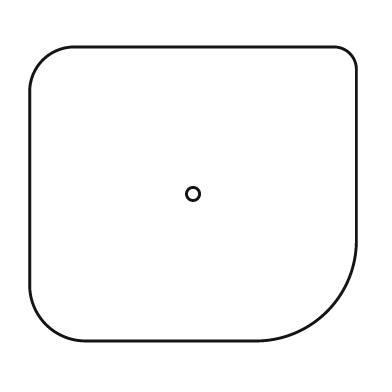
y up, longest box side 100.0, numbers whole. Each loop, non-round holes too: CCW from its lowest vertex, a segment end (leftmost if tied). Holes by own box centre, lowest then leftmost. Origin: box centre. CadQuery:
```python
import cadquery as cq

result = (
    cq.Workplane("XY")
    .moveTo(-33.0, -45.0)
    .lineTo(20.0, -45.0)
    .threePointArc((41.0, -36.0), (50.0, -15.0))
    .lineTo(50.0, 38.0)
    .threePointArc((48.0, 43.0), (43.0, 45.0))
    .lineTo(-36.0, 45.0)
    .threePointArc((-46.0, 41.0), (-50.0, 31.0))
    .lineTo(-50.0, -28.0)
    .threePointArc((-45.0, -40.0), (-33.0, -45.0))
    .close()
    .moveTo(0.0, 0.0)
    .circle(2.0)
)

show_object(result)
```